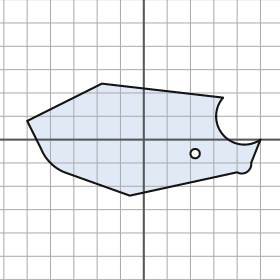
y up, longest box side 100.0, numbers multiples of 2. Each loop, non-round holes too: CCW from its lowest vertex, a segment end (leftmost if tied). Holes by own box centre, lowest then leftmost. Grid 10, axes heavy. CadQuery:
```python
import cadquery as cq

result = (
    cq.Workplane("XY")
    .moveTo(-6.0, -24.0)
    .lineTo(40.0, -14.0)
    .threePointArc((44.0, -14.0), (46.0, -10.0))
    .lineTo(50.0, 0.0)
    .threePointArc((34.0, 2.0), (34.0, 18.0))
    .lineTo(-18.0, 24.0)
    .lineTo(-50.0, 8.0)
    .lineTo(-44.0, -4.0)
    .threePointArc((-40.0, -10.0), (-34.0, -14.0))
    .close()
    .moveTo(22.0, -6.0)
    .circle(2.0)
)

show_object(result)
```